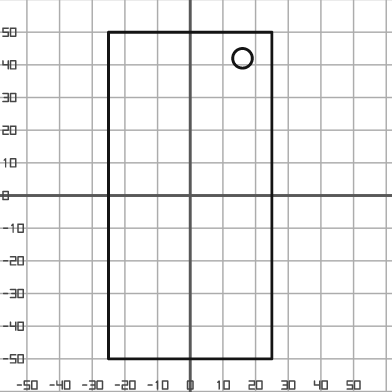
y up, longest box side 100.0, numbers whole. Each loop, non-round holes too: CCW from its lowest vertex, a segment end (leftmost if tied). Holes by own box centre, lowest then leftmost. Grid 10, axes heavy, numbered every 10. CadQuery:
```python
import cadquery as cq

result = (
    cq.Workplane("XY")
    .moveTo(-25.0, -50.0)
    .lineTo(25.0, -50.0)
    .lineTo(25.0, 50.0)
    .lineTo(-25.0, 50.0)
    .close()
    .moveTo(16.0, 42.0)
    .circle(3.0)
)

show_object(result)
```